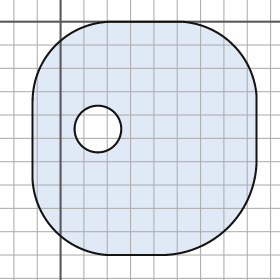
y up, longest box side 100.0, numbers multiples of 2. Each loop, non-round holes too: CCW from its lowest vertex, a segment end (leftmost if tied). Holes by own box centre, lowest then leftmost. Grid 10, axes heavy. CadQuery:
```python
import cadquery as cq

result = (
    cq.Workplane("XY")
    .moveTo(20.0, -100.0)
    .lineTo(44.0, -100.0)
    .threePointArc((72.0, -88.0), (84.0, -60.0))
    .lineTo(84.0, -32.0)
    .threePointArc((74.0, -10.0), (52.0, 0.0))
    .lineTo(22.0, 0.0)
    .threePointArc((-2.0, -10.0), (-12.0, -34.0))
    .lineTo(-12.0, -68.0)
    .threePointArc((-2.0, -90.0), (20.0, -100.0))
    .close()
    .moveTo(16.0, -46.0)
    .circle(10.0)
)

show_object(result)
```